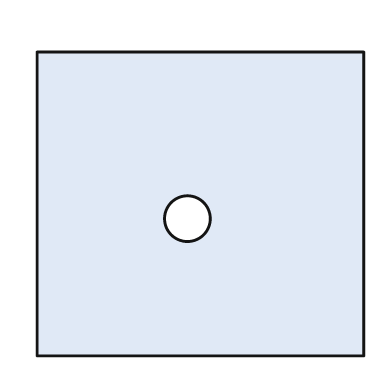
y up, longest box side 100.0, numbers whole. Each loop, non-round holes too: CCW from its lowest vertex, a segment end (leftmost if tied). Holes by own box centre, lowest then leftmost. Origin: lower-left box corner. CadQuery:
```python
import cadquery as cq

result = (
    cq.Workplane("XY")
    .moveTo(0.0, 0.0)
    .lineTo(100.0, 0.0)
    .lineTo(100.0, 93.0)
    .lineTo(0.0, 93.0)
    .close()
    .moveTo(46.0, 42.0)
    .circle(7.0)
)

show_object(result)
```